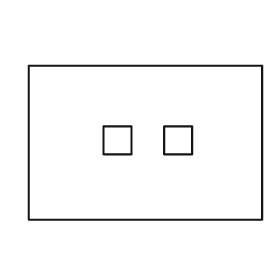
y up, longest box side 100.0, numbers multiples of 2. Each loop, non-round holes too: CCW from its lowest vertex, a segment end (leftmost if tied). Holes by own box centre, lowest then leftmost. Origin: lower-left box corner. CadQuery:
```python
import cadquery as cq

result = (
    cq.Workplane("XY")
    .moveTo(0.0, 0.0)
    .lineTo(100.0, 0.0)
    .lineTo(100.0, 66.0)
    .lineTo(0.0, 66.0)
    .close()
    .moveTo(32.0, 28.0)
    .lineTo(44.0, 28.0)
    .lineTo(44.0, 40.0)
    .lineTo(32.0, 40.0)
    .close()
    .moveTo(58.0, 28.0)
    .lineTo(70.0, 28.0)
    .lineTo(70.0, 40.0)
    .lineTo(58.0, 40.0)
    .close()
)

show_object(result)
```